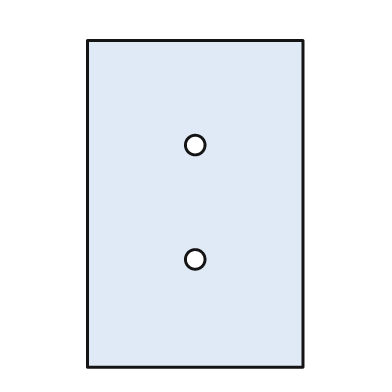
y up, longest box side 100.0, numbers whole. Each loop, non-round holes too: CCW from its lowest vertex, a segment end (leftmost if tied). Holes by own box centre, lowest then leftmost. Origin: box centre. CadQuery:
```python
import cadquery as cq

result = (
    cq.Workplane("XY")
    .moveTo(-33.0, -50.0)
    .lineTo(33.0, -50.0)
    .lineTo(33.0, 50.0)
    .lineTo(-33.0, 50.0)
    .close()
    .moveTo(0.0, -17.0)
    .circle(3.0)
    .moveTo(0.0, 18.0)
    .circle(3.0)
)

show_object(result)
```